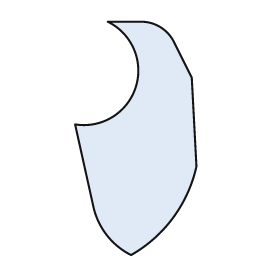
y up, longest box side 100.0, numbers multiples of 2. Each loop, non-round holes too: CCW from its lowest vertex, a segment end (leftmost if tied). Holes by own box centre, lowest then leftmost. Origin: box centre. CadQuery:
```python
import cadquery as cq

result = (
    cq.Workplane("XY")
    .moveTo(-2.0, -50.0)
    .threePointArc((16.0, -34.0), (26.0, -12.0))
    .lineTo(24.0, 26.0)
    .lineTo(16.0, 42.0)
    .threePointArc((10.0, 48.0), (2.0, 50.0))
    .lineTo(-12.0, 50.0)
    .threePointArc((0.0, 22.0), (-26.0, 6.0))
    .lineTo(-18.0, -30.0)
    .threePointArc((-12.0, -42.0), (-2.0, -50.0))
    .close()
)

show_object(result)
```